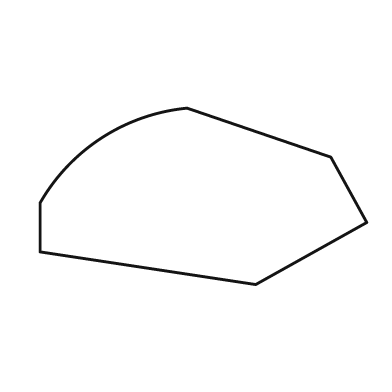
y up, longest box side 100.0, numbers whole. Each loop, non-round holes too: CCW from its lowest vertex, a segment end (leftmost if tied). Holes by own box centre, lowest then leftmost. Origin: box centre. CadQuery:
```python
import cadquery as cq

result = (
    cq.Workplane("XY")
    .moveTo(16.0, -27.0)
    .lineTo(50.0, -8.0)
    .lineTo(39.0, 12.0)
    .lineTo(-5.0, 27.0)
    .threePointArc((-31.0, 18.0), (-50.0, -2.0))
    .lineTo(-50.0, -17.0)
    .close()
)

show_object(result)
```